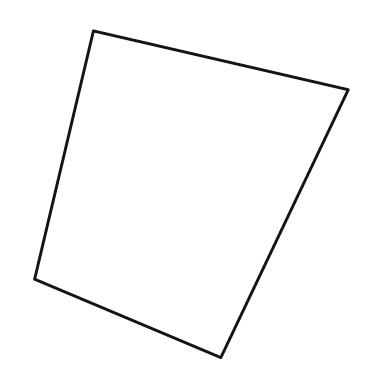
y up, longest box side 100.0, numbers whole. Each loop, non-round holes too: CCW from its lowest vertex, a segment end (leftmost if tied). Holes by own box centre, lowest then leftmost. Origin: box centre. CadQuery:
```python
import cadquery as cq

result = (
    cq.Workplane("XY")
    .moveTo(9.0, -50.0)
    .lineTo(48.0, 32.0)
    .lineTo(-30.0, 50.0)
    .lineTo(-48.0, -26.0)
    .close()
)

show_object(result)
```